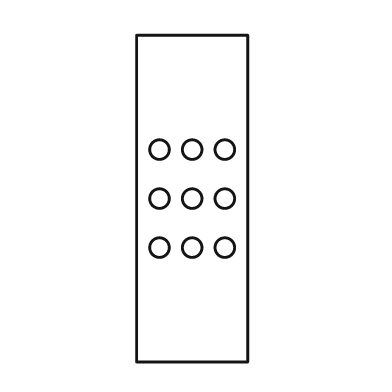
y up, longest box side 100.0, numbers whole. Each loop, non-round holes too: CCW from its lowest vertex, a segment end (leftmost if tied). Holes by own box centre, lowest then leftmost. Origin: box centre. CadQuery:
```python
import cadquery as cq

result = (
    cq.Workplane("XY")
    .moveTo(-17.0, -50.0)
    .lineTo(17.0, -50.0)
    .lineTo(17.0, 50.0)
    .lineTo(-17.0, 50.0)
    .close()
    .moveTo(-10.0, -15.0)
    .circle(3.0)
    .moveTo(0.0, -15.0)
    .circle(3.0)
    .moveTo(10.0, -15.0)
    .circle(3.0)
    .moveTo(-10.0, 0.0)
    .circle(3.0)
    .moveTo(0.0, 0.0)
    .circle(3.0)
    .moveTo(10.0, 0.0)
    .circle(3.0)
    .moveTo(-10.0, 15.0)
    .circle(3.0)
    .moveTo(0.0, 15.0)
    .circle(3.0)
    .moveTo(10.0, 15.0)
    .circle(3.0)
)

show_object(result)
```